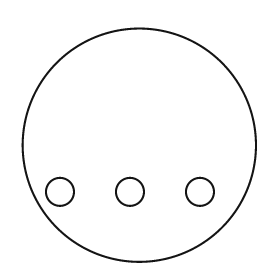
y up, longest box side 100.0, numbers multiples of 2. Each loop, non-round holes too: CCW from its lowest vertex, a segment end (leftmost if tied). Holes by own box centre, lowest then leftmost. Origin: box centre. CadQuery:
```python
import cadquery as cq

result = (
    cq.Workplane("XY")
    .moveTo(0.0, 0.0)
    .circle(50.0)
    .moveTo(-34.0, -20.0)
    .circle(6.0)
    .moveTo(-4.0, -20.0)
    .circle(6.0)
    .moveTo(26.0, -20.0)
    .circle(6.0)
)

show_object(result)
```